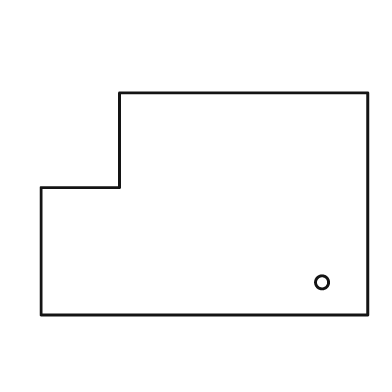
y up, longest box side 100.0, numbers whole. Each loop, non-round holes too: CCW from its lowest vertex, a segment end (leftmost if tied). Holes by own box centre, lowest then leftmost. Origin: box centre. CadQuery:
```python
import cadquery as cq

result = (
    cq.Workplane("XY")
    .moveTo(-50.0, -34.0)
    .lineTo(50.0, -34.0)
    .lineTo(50.0, 34.0)
    .lineTo(-26.0, 34.0)
    .lineTo(-26.0, 5.0)
    .lineTo(-50.0, 5.0)
    .close()
    .moveTo(36.0, -24.0)
    .circle(2.0)
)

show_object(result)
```